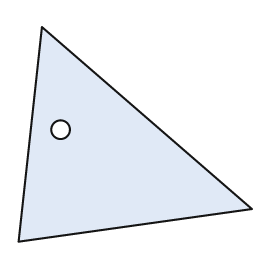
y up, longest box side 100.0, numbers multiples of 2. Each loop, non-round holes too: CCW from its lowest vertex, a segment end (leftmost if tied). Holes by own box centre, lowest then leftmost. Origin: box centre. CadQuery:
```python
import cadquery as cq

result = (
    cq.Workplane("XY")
    .moveTo(-50.0, -46.0)
    .lineTo(50.0, -32.0)
    .lineTo(-40.0, 46.0)
    .close()
    .moveTo(-32.0, 2.0)
    .circle(4.0)
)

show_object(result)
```